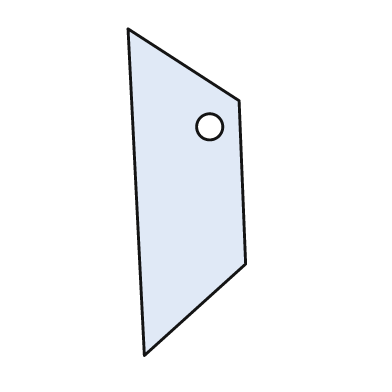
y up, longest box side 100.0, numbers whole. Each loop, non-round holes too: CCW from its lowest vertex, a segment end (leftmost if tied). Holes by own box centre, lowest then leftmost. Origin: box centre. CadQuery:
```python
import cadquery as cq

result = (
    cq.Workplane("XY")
    .moveTo(-13.0, -50.0)
    .lineTo(18.0, -22.0)
    .lineTo(16.0, 28.0)
    .lineTo(-18.0, 50.0)
    .close()
    .moveTo(7.0, 20.0)
    .circle(4.0)
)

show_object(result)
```